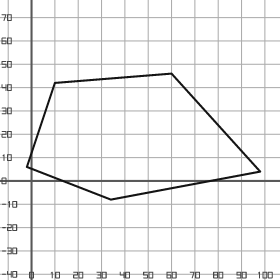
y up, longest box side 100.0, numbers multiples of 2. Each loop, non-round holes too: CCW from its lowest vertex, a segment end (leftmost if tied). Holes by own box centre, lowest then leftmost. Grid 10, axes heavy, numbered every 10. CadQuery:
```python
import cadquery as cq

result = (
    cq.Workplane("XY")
    .moveTo(34.0, -8.0)
    .lineTo(98.0, 4.0)
    .lineTo(60.0, 46.0)
    .lineTo(10.0, 42.0)
    .lineTo(-2.0, 6.0)
    .close()
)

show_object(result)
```